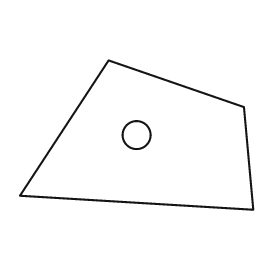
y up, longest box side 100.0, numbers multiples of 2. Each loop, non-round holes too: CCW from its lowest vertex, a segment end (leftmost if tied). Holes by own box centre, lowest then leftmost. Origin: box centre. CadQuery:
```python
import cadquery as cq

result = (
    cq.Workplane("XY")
    .moveTo(50.0, -32.0)
    .lineTo(46.0, 12.0)
    .lineTo(-12.0, 32.0)
    .lineTo(-50.0, -26.0)
    .close()
    .moveTo(0.0, 0.0)
    .circle(6.0)
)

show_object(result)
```